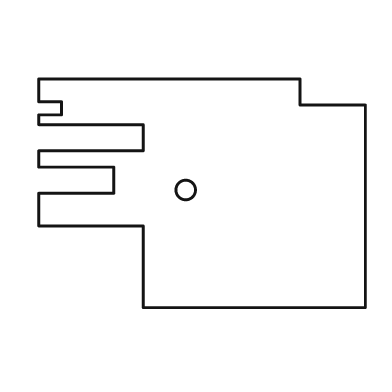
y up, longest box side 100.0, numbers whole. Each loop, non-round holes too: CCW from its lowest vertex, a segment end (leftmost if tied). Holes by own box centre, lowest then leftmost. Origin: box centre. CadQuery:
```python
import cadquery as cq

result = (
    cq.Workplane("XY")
    .moveTo(-18.0, -35.0)
    .lineTo(50.0, -35.0)
    .lineTo(50.0, 27.0)
    .lineTo(30.0, 27.0)
    .lineTo(30.0, 35.0)
    .lineTo(-50.0, 35.0)
    .lineTo(-50.0, 28.0)
    .lineTo(-43.0, 28.0)
    .lineTo(-43.0, 24.0)
    .lineTo(-50.0, 24.0)
    .lineTo(-50.0, 21.0)
    .lineTo(-18.0, 21.0)
    .lineTo(-18.0, 13.0)
    .lineTo(-50.0, 13.0)
    .lineTo(-50.0, 8.0)
    .lineTo(-27.0, 8.0)
    .lineTo(-27.0, 0.0)
    .lineTo(-50.0, 0.0)
    .lineTo(-50.0, -10.0)
    .lineTo(-18.0, -10.0)
    .close()
    .moveTo(-5.0, 1.0)
    .circle(3.0)
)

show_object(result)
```